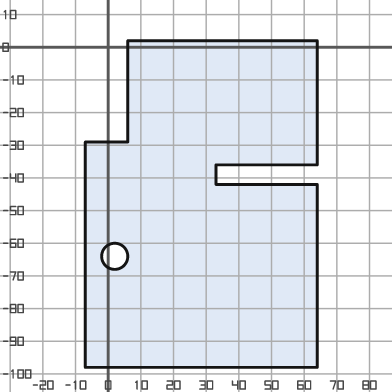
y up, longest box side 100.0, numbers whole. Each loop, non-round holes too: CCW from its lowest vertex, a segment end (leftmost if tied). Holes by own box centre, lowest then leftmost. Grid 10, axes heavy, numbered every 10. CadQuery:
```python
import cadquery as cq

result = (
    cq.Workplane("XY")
    .moveTo(-7.0, -98.0)
    .lineTo(64.0, -98.0)
    .lineTo(64.0, -42.0)
    .lineTo(33.0, -42.0)
    .lineTo(33.0, -36.0)
    .lineTo(64.0, -36.0)
    .lineTo(64.0, 2.0)
    .lineTo(6.0, 2.0)
    .lineTo(6.0, -29.0)
    .lineTo(-7.0, -29.0)
    .close()
    .moveTo(2.0, -64.0)
    .circle(4.0)
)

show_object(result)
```